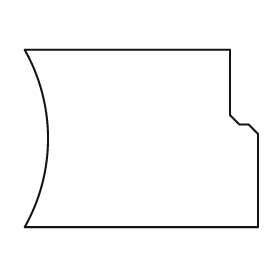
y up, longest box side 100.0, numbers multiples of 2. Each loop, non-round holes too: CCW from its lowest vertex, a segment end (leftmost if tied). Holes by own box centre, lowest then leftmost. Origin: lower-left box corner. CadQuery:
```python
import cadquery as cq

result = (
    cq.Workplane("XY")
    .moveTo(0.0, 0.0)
    .lineTo(100.0, 0.0)
    .lineTo(100.0, 40.0)
    .lineTo(96.0, 44.0)
    .lineTo(92.0, 44.0)
    .lineTo(88.0, 48.0)
    .lineTo(88.0, 76.0)
    .lineTo(0.0, 76.0)
    .threePointArc((10.0, 38.0), (0.0, 0.0))
    .close()
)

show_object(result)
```